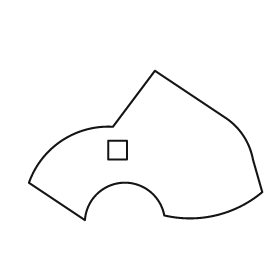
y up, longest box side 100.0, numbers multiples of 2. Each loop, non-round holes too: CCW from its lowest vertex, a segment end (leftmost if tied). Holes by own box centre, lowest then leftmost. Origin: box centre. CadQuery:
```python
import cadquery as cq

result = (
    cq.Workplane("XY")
    .moveTo(-26.0, -32.0)
    .threePointArc((-10.0, -16.0), (8.0, -30.0))
    .threePointArc((30.0, -30.0), (50.0, -20.0))
    .lineTo(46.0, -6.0)
    .threePointArc((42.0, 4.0), (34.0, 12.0))
    .lineTo(4.0, 32.0)
    .lineTo(-14.0, 8.0)
    .threePointArc((-36.0, 2.0), (-50.0, -16.0))
    .close()
    .moveTo(-16.0, -6.0)
    .lineTo(-8.0, -6.0)
    .lineTo(-8.0, 2.0)
    .lineTo(-16.0, 2.0)
    .close()
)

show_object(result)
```